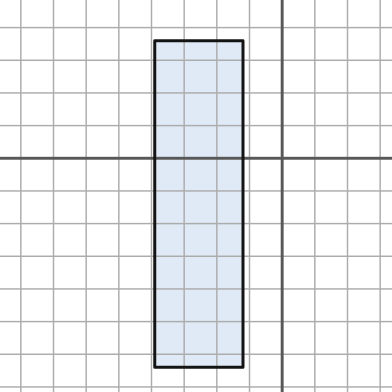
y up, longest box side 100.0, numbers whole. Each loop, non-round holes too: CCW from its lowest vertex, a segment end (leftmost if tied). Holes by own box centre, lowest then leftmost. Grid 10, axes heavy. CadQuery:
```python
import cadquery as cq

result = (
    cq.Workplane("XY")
    .moveTo(-39.0, -64.0)
    .lineTo(-12.0, -64.0)
    .lineTo(-12.0, 36.0)
    .lineTo(-39.0, 36.0)
    .close()
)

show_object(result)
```